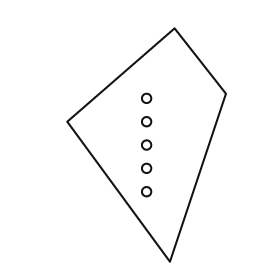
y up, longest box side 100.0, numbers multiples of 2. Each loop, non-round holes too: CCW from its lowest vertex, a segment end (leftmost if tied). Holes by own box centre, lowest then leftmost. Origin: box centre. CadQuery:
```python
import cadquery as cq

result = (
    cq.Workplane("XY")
    .moveTo(10.0, -50.0)
    .lineTo(34.0, 22.0)
    .lineTo(12.0, 50.0)
    .lineTo(-34.0, 10.0)
    .close()
    .moveTo(0.0, -20.0)
    .circle(2.0)
    .moveTo(0.0, -10.0)
    .circle(2.0)
    .moveTo(0.0, 0.0)
    .circle(2.0)
    .moveTo(0.0, 10.0)
    .circle(2.0)
    .moveTo(0.0, 20.0)
    .circle(2.0)
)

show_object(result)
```